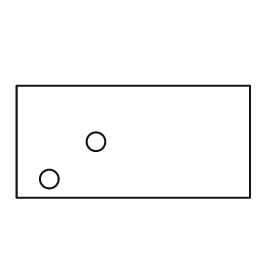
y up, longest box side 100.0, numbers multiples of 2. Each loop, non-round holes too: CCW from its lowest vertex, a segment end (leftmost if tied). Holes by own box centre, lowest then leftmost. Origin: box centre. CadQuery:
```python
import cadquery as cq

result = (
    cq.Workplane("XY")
    .moveTo(-50.0, -24.0)
    .lineTo(50.0, -24.0)
    .lineTo(50.0, 24.0)
    .lineTo(-50.0, 24.0)
    .close()
    .moveTo(-36.0, -16.0)
    .circle(4.0)
    .moveTo(-16.0, 0.0)
    .circle(4.0)
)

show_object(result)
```